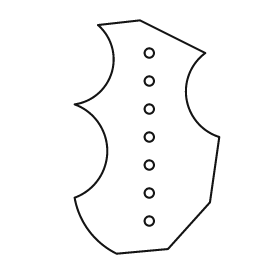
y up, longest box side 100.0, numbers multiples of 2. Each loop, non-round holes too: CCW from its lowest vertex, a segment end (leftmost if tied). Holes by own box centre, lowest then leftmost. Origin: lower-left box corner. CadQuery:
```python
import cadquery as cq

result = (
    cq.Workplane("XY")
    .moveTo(18.0, 0.0)
    .lineTo(40.0, 2.0)
    .lineTo(58.0, 22.0)
    .lineTo(62.0, 50.0)
    .threePointArc((48.0, 66.0), (56.0, 86.0))
    .lineTo(28.0, 100.0)
    .lineTo(10.0, 98.0)
    .threePointArc((16.0, 78.0), (0.0, 64.0))
    .threePointArc((14.0, 44.0), (0.0, 24.0))
    .threePointArc((6.0, 10.0), (18.0, 0.0))
    .close()
    .moveTo(32.0, 14.0)
    .circle(2.0)
    .moveTo(32.0, 26.0)
    .circle(2.0)
    .moveTo(32.0, 38.0)
    .circle(2.0)
    .moveTo(32.0, 50.0)
    .circle(2.0)
    .moveTo(32.0, 62.0)
    .circle(2.0)
    .moveTo(32.0, 74.0)
    .circle(2.0)
    .moveTo(32.0, 86.0)
    .circle(2.0)
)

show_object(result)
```